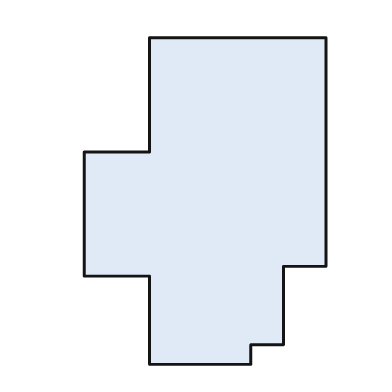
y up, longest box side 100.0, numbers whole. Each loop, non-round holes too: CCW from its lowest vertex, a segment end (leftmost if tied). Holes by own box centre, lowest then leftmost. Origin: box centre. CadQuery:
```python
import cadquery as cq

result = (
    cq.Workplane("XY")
    .moveTo(-17.0, -50.0)
    .lineTo(14.0, -50.0)
    .lineTo(14.0, -44.0)
    .lineTo(24.0, -44.0)
    .lineTo(24.0, -20.0)
    .lineTo(37.0, -20.0)
    .lineTo(37.0, 50.0)
    .lineTo(-17.0, 50.0)
    .lineTo(-17.0, 15.0)
    .lineTo(-37.0, 15.0)
    .lineTo(-37.0, -23.0)
    .lineTo(-17.0, -23.0)
    .close()
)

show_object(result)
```